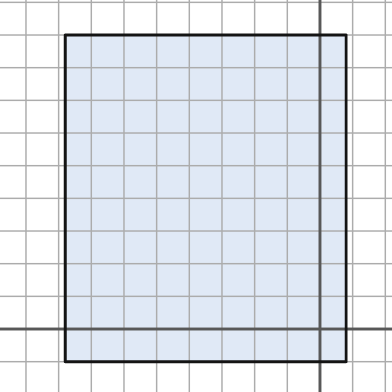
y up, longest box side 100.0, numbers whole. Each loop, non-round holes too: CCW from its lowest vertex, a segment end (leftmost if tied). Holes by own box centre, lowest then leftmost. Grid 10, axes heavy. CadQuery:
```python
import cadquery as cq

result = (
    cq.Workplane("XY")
    .moveTo(-78.0, -10.0)
    .lineTo(8.0, -10.0)
    .lineTo(8.0, 90.0)
    .lineTo(-78.0, 90.0)
    .close()
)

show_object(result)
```